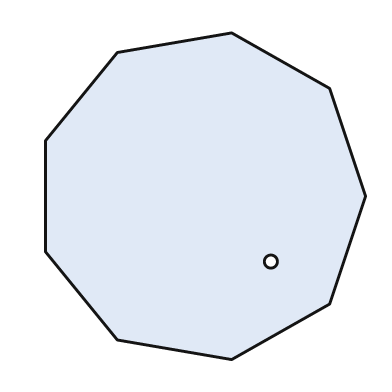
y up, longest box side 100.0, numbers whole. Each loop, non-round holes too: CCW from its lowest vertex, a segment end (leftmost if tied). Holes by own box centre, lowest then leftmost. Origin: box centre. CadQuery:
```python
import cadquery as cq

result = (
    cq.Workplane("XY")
    .moveTo(8.0, -50.0)
    .lineTo(38.0, -33.0)
    .lineTo(49.0, 0.0)
    .lineTo(38.0, 33.0)
    .lineTo(8.0, 50.0)
    .lineTo(-27.0, 44.0)
    .lineTo(-49.0, 17.0)
    .lineTo(-49.0, -17.0)
    .lineTo(-27.0, -44.0)
    .close()
    .moveTo(20.0, -20.0)
    .circle(2.0)
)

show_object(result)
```